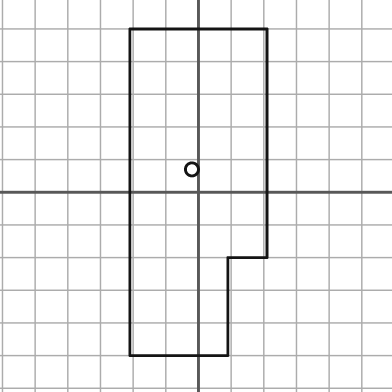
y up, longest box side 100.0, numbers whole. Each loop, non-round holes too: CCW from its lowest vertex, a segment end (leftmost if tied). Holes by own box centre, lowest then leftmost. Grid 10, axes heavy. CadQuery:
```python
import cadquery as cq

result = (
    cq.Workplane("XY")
    .moveTo(-21.0, -50.0)
    .lineTo(9.0, -50.0)
    .lineTo(9.0, -20.0)
    .lineTo(21.0, -20.0)
    .lineTo(21.0, 50.0)
    .lineTo(-21.0, 50.0)
    .close()
    .moveTo(-2.0, 7.0)
    .circle(2.0)
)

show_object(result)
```